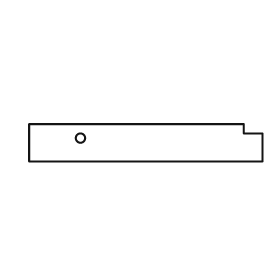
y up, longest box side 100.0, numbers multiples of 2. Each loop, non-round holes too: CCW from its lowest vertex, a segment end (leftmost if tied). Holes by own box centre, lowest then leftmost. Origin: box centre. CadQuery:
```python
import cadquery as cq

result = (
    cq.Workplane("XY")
    .moveTo(-50.0, -8.0)
    .lineTo(50.0, -8.0)
    .lineTo(50.0, 4.0)
    .lineTo(42.0, 4.0)
    .lineTo(42.0, 8.0)
    .lineTo(-50.0, 8.0)
    .close()
    .moveTo(-28.0, 2.0)
    .circle(2.0)
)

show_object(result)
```